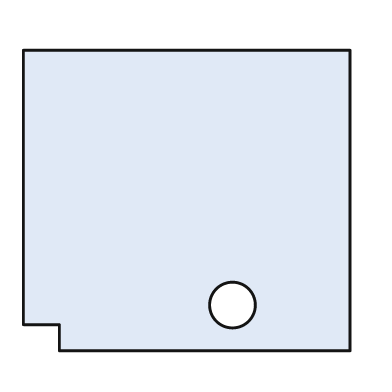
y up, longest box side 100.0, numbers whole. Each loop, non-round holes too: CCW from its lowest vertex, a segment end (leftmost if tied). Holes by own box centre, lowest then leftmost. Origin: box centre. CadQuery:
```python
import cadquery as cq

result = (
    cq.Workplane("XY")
    .moveTo(-39.0, -46.0)
    .lineTo(50.0, -46.0)
    .lineTo(50.0, 46.0)
    .lineTo(-50.0, 46.0)
    .lineTo(-50.0, -38.0)
    .lineTo(-39.0, -38.0)
    .close()
    .moveTo(14.0, -32.0)
    .circle(7.0)
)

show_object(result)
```